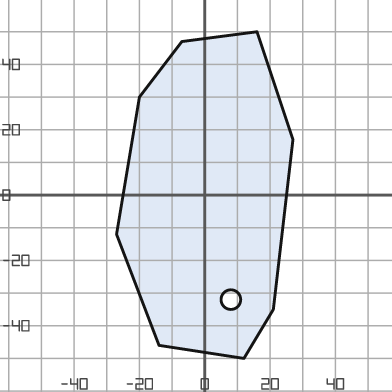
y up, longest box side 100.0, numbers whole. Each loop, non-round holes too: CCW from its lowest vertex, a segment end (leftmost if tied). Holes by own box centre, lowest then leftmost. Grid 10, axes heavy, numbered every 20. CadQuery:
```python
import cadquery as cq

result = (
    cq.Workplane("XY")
    .moveTo(12.0, -50.0)
    .lineTo(21.0, -35.0)
    .lineTo(27.0, 17.0)
    .lineTo(16.0, 50.0)
    .lineTo(-7.0, 47.0)
    .lineTo(-20.0, 30.0)
    .lineTo(-27.0, -12.0)
    .lineTo(-14.0, -46.0)
    .close()
    .moveTo(8.0, -32.0)
    .circle(3.0)
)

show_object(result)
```